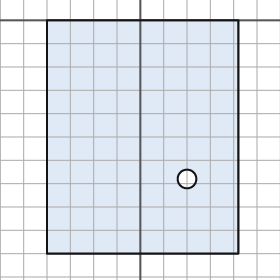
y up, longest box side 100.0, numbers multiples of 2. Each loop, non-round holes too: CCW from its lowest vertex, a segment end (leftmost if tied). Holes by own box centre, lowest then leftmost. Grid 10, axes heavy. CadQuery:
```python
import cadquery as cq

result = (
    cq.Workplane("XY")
    .moveTo(-40.0, -100.0)
    .lineTo(42.0, -100.0)
    .lineTo(42.0, 0.0)
    .lineTo(-40.0, 0.0)
    .close()
    .moveTo(20.0, -68.0)
    .circle(4.0)
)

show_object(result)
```